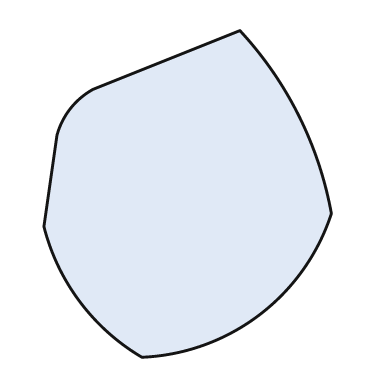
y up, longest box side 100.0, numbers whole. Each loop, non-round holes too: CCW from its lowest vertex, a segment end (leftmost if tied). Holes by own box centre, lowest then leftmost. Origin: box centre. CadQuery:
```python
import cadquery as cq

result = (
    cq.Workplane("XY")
    .moveTo(-14.0, -50.0)
    .threePointArc((22.0, -37.0), (44.0, -6.0))
    .threePointArc((34.0, 24.0), (16.0, 50.0))
    .lineTo(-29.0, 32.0)
    .threePointArc((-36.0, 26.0), (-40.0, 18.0))
    .lineTo(-44.0, -10.0)
    .threePointArc((-33.0, -33.0), (-14.0, -50.0))
    .close()
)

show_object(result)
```